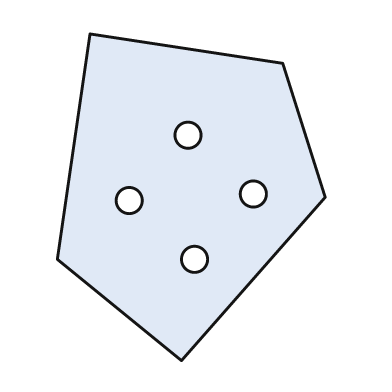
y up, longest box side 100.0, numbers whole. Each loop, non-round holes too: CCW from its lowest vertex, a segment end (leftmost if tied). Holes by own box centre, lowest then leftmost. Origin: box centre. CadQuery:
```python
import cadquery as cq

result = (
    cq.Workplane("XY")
    .moveTo(-3.0, -50.0)
    .lineTo(41.0, 0.0)
    .lineTo(28.0, 41.0)
    .lineTo(-31.0, 50.0)
    .lineTo(-41.0, -19.0)
    .close()
    .moveTo(1.0, -19.0)
    .circle(4.0)
    .moveTo(-19.0, -1.0)
    .circle(4.0)
    .moveTo(19.0, 1.0)
    .circle(4.0)
    .moveTo(-1.0, 19.0)
    .circle(4.0)
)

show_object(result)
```